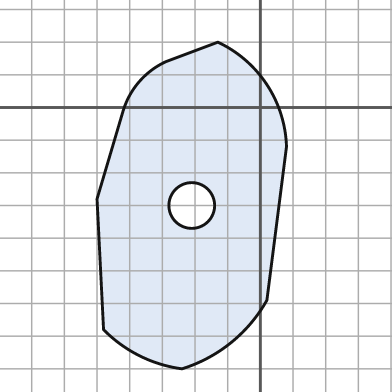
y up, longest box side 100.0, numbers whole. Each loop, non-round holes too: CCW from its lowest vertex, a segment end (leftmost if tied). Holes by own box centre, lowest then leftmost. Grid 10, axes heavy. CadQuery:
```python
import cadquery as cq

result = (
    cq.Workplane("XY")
    .moveTo(-24.0, -80.0)
    .threePointArc((-9.0, -72.0), (2.0, -59.0))
    .lineTo(8.0, -12.0)
    .threePointArc((2.0, 7.0), (-13.0, 20.0))
    .lineTo(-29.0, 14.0)
    .threePointArc((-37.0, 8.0), (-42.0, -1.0))
    .lineTo(-50.0, -28.0)
    .lineTo(-48.0, -68.0)
    .threePointArc((-37.0, -76.0), (-24.0, -80.0))
    .close()
    .moveTo(-21.0, -30.0)
    .circle(7.0)
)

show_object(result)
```